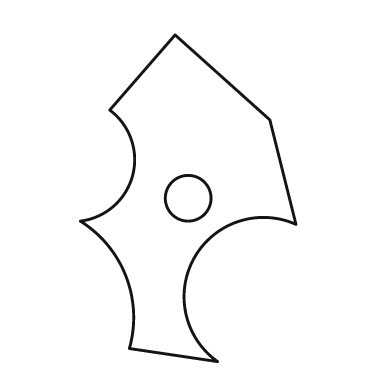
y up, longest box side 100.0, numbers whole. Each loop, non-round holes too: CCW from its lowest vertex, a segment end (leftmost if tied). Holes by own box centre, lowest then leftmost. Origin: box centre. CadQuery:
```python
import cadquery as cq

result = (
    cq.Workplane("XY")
    .moveTo(9.0, -50.0)
    .threePointArc((2.0, -18.0), (33.0, -8.0))
    .lineTo(25.0, 24.0)
    .lineTo(-4.0, 50.0)
    .lineTo(-24.0, 27.0)
    .threePointArc((-17.0, 7.0), (-33.0, -7.0))
    .threePointArc((-19.0, -24.0), (-18.0, -46.0))
    .close()
    .moveTo(0.0, 0.0)
    .circle(7.0)
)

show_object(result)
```